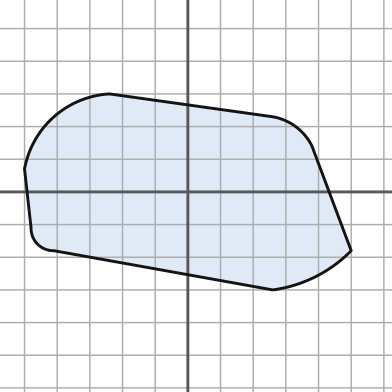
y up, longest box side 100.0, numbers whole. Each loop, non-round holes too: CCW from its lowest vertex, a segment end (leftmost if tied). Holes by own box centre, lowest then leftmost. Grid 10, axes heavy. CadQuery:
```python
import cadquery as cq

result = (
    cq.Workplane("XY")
    .moveTo(26.0, -30.0)
    .threePointArc((39.0, -26.0), (50.0, -18.0))
    .lineTo(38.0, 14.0)
    .threePointArc((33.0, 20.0), (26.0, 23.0))
    .lineTo(-24.0, 30.0)
    .threePointArc((-41.0, 23.0), (-50.0, 7.0))
    .lineTo(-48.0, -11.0)
    .threePointArc((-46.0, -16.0), (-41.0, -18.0))
    .close()
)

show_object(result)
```